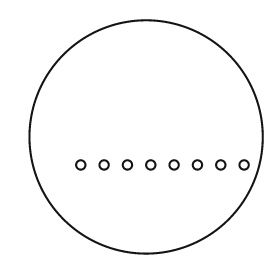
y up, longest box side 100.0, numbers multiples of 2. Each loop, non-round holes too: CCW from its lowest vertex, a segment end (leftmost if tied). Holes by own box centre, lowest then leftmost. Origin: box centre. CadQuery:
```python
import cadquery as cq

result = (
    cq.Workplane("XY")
    .moveTo(0.0, 0.0)
    .circle(50.0)
    .moveTo(-28.0, -12.0)
    .circle(2.0)
    .moveTo(-18.0, -12.0)
    .circle(2.0)
    .moveTo(-8.0, -12.0)
    .circle(2.0)
    .moveTo(2.0, -12.0)
    .circle(2.0)
    .moveTo(12.0, -12.0)
    .circle(2.0)
    .moveTo(22.0, -12.0)
    .circle(2.0)
    .moveTo(32.0, -12.0)
    .circle(2.0)
    .moveTo(42.0, -12.0)
    .circle(2.0)
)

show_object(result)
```